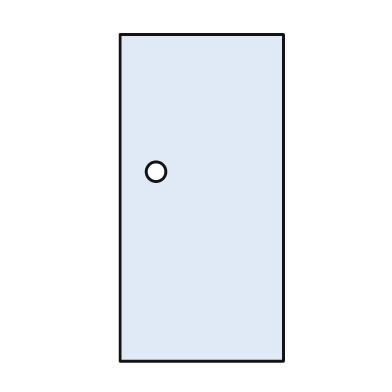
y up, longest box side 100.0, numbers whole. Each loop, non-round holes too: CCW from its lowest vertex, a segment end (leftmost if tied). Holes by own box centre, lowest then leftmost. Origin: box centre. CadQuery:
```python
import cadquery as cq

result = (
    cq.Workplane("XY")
    .moveTo(-25.0, -50.0)
    .lineTo(25.0, -50.0)
    .lineTo(25.0, 50.0)
    .lineTo(-25.0, 50.0)
    .close()
    .moveTo(-14.0, 8.0)
    .circle(3.0)
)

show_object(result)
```